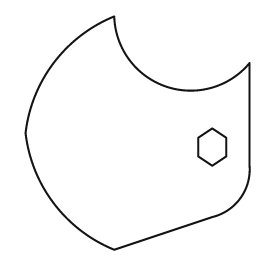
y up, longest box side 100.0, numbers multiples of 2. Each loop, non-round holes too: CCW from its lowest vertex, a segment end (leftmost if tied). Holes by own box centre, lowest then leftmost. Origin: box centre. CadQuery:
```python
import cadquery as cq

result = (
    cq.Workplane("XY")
    .moveTo(-10.0, -50.0)
    .lineTo(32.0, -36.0)
    .threePointArc((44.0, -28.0), (48.0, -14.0))
    .lineTo(48.0, 30.0)
    .threePointArc((12.0, 20.0), (-10.0, 50.0))
    .threePointArc((-36.0, 30.0), (-48.0, 0.0))
    .threePointArc((-36.0, -30.0), (-10.0, -50.0))
    .close()
    .moveTo(32.0, -14.0)
    .lineTo(38.0, -10.0)
    .lineTo(38.0, -2.0)
    .lineTo(32.0, 2.0)
    .lineTo(26.0, -2.0)
    .lineTo(26.0, -10.0)
    .close()
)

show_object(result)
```